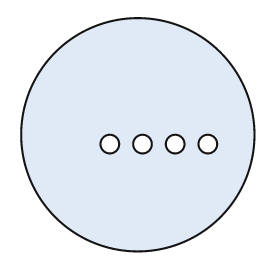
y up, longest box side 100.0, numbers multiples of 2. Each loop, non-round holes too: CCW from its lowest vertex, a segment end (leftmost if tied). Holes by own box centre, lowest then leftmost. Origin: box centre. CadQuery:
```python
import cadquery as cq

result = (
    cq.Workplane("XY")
    .moveTo(0.0, 0.0)
    .circle(50.0)
    .moveTo(-12.0, -4.0)
    .circle(4.0)
    .moveTo(2.0, -4.0)
    .circle(4.0)
    .moveTo(16.0, -4.0)
    .circle(4.0)
    .moveTo(30.0, -4.0)
    .circle(4.0)
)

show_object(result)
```